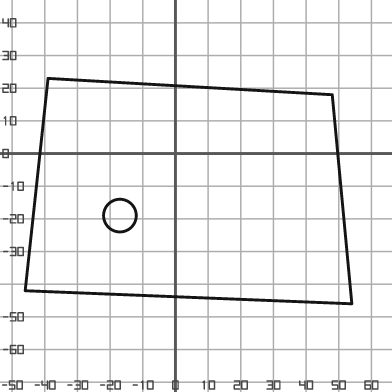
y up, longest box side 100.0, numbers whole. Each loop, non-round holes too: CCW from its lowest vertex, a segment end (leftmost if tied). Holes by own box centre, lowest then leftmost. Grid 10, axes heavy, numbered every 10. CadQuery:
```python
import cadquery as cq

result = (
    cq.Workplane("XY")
    .moveTo(54.0, -46.0)
    .lineTo(48.0, 18.0)
    .lineTo(-39.0, 23.0)
    .lineTo(-46.0, -42.0)
    .close()
    .moveTo(-17.0, -19.0)
    .circle(5.0)
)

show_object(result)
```